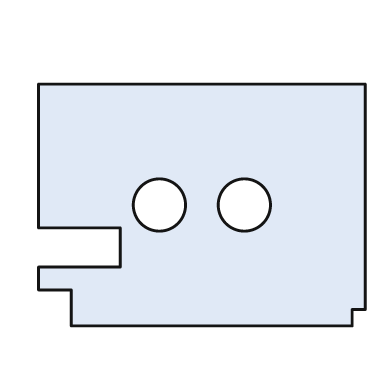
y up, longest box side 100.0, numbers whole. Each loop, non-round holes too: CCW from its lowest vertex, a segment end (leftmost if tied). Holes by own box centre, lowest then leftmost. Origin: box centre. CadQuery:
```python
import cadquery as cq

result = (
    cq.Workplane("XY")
    .moveTo(-40.0, -37.0)
    .lineTo(46.0, -37.0)
    .lineTo(46.0, -32.0)
    .lineTo(50.0, -32.0)
    .lineTo(50.0, 37.0)
    .lineTo(-50.0, 37.0)
    .lineTo(-50.0, -7.0)
    .lineTo(-25.0, -7.0)
    .lineTo(-25.0, -19.0)
    .lineTo(-50.0, -19.0)
    .lineTo(-50.0, -26.0)
    .lineTo(-40.0, -26.0)
    .close()
    .moveTo(-13.0, 0.0)
    .circle(8.0)
    .moveTo(13.0, 0.0)
    .circle(8.0)
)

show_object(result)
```